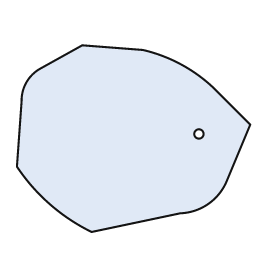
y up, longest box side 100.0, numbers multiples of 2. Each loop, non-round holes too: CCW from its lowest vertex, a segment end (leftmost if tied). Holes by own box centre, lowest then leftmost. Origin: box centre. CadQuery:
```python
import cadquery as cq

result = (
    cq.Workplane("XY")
    .moveTo(-18.0, -40.0)
    .lineTo(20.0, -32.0)
    .threePointArc((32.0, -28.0), (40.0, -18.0))
    .lineTo(50.0, 6.0)
    .lineTo(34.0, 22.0)
    .threePointArc((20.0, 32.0), (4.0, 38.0))
    .lineTo(-22.0, 40.0)
    .lineTo(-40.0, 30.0)
    .threePointArc((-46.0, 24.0), (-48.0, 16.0))
    .lineTo(-50.0, -12.0)
    .threePointArc((-36.0, -28.0), (-18.0, -40.0))
    .close()
    .moveTo(28.0, 2.0)
    .circle(2.0)
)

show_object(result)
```